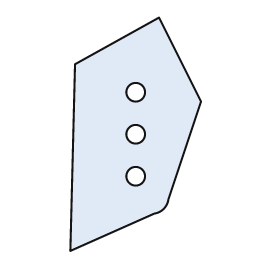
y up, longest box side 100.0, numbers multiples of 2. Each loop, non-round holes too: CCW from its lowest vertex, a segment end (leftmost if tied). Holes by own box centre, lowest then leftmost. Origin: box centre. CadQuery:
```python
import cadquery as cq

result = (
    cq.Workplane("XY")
    .moveTo(-28.0, -50.0)
    .lineTo(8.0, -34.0)
    .threePointArc((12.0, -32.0), (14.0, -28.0))
    .lineTo(28.0, 14.0)
    .lineTo(10.0, 50.0)
    .lineTo(-26.0, 30.0)
    .close()
    .moveTo(0.0, -18.0)
    .circle(4.0)
    .moveTo(0.0, 0.0)
    .circle(4.0)
    .moveTo(0.0, 18.0)
    .circle(4.0)
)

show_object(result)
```